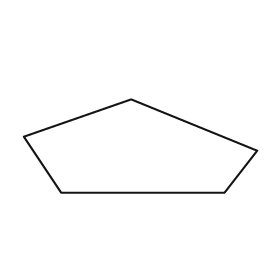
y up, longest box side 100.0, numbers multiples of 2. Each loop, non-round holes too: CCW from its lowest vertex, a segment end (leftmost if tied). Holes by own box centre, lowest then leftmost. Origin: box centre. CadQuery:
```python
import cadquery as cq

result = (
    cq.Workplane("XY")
    .moveTo(-34.0, -20.0)
    .lineTo(36.0, -20.0)
    .lineTo(50.0, -2.0)
    .lineTo(-4.0, 20.0)
    .lineTo(-50.0, 4.0)
    .close()
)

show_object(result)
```